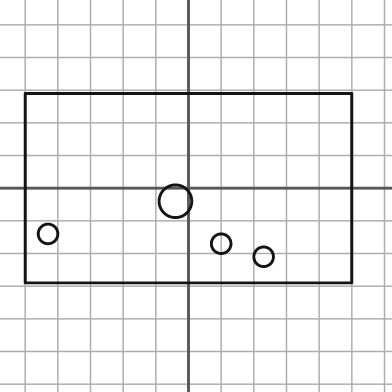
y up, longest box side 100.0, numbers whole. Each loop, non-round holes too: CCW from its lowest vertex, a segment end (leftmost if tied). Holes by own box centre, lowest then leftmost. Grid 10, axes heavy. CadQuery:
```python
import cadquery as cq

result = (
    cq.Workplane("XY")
    .moveTo(-50.0, -29.0)
    .lineTo(50.0, -29.0)
    .lineTo(50.0, 29.0)
    .lineTo(-50.0, 29.0)
    .close()
    .moveTo(23.0, -21.0)
    .circle(3.0)
    .moveTo(10.0, -17.0)
    .circle(3.0)
    .moveTo(-43.0, -14.0)
    .circle(3.0)
    .moveTo(-4.0, -4.0)
    .circle(5.0)
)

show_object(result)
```